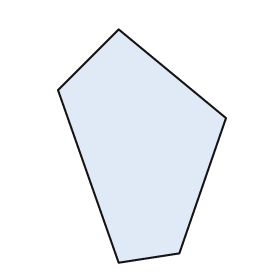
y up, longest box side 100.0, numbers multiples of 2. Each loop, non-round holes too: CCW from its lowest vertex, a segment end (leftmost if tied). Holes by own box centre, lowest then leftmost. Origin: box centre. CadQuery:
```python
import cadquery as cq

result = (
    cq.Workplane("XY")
    .moveTo(-10.0, -50.0)
    .lineTo(16.0, -46.0)
    .lineTo(36.0, 12.0)
    .lineTo(-10.0, 50.0)
    .lineTo(-36.0, 24.0)
    .close()
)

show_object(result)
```